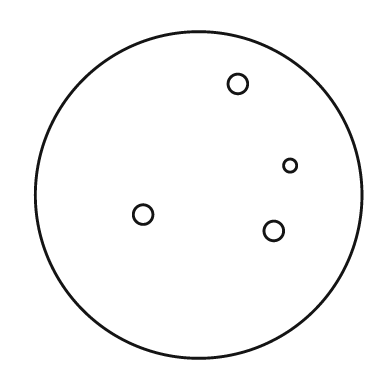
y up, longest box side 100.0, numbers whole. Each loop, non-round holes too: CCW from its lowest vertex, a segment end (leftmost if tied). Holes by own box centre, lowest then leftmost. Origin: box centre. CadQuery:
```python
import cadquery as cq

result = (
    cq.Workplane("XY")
    .moveTo(0.0, 0.0)
    .circle(50.0)
    .moveTo(23.0, -11.0)
    .circle(3.0)
    .moveTo(-17.0, -6.0)
    .circle(3.0)
    .moveTo(28.0, 9.0)
    .circle(2.0)
    .moveTo(12.0, 34.0)
    .circle(3.0)
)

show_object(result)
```